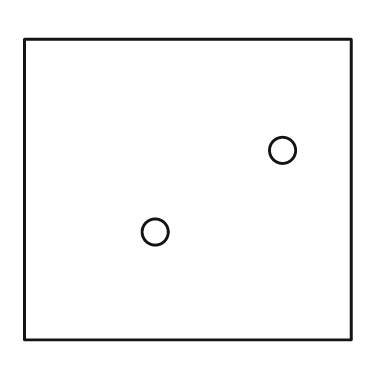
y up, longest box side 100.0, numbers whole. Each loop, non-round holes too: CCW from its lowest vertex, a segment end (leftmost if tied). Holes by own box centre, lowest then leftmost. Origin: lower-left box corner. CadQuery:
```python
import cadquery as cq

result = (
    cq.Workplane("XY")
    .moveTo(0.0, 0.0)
    .lineTo(100.0, 0.0)
    .lineTo(100.0, 92.0)
    .lineTo(0.0, 92.0)
    .close()
    .moveTo(40.0, 33.0)
    .circle(4.0)
    .moveTo(79.0, 58.0)
    .circle(4.0)
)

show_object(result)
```